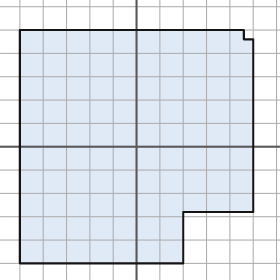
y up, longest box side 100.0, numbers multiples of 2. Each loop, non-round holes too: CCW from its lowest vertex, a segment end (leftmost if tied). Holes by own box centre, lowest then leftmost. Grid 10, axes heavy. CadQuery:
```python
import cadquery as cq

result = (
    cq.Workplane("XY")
    .moveTo(-50.0, -50.0)
    .lineTo(20.0, -50.0)
    .lineTo(20.0, -28.0)
    .lineTo(50.0, -28.0)
    .lineTo(50.0, 46.0)
    .lineTo(46.0, 46.0)
    .lineTo(46.0, 50.0)
    .lineTo(-50.0, 50.0)
    .close()
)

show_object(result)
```